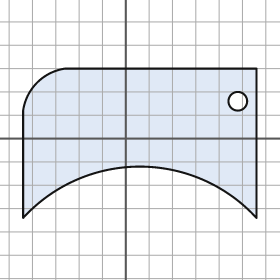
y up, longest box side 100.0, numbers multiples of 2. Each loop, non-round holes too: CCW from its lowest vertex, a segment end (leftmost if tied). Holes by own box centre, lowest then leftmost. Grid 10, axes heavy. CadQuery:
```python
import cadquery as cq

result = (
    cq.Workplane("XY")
    .moveTo(-44.0, -34.0)
    .threePointArc((6.0, -12.0), (56.0, -34.0))
    .lineTo(56.0, 30.0)
    .lineTo(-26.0, 30.0)
    .threePointArc((-38.0, 24.0), (-44.0, 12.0))
    .close()
    .moveTo(48.0, 16.0)
    .circle(4.0)
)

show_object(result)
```